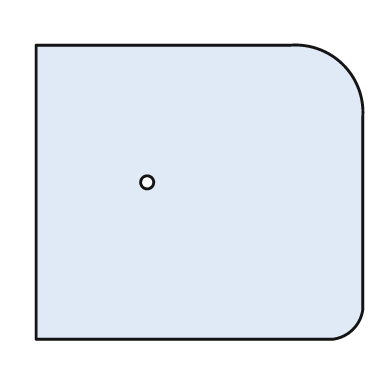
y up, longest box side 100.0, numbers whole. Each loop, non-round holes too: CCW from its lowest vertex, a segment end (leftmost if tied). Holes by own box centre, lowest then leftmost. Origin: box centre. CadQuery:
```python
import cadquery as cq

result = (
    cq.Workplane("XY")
    .moveTo(-50.0, -45.0)
    .lineTo(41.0, -45.0)
    .threePointArc((47.0, -42.0), (50.0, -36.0))
    .lineTo(50.0, 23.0)
    .threePointArc((44.0, 39.0), (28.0, 45.0))
    .lineTo(-50.0, 45.0)
    .close()
    .moveTo(-16.0, 3.0)
    .circle(2.0)
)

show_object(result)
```